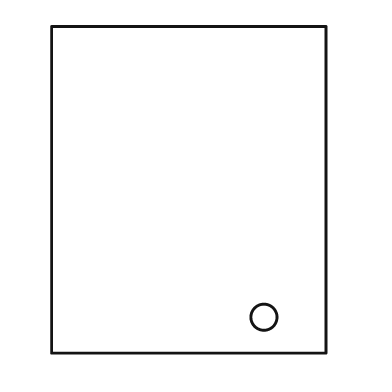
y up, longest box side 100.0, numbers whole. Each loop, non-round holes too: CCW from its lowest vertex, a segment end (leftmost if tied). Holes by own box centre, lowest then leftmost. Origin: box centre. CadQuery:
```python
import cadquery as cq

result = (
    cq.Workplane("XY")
    .moveTo(-42.0, -50.0)
    .lineTo(42.0, -50.0)
    .lineTo(42.0, 50.0)
    .lineTo(-42.0, 50.0)
    .close()
    .moveTo(23.0, -39.0)
    .circle(4.0)
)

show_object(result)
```